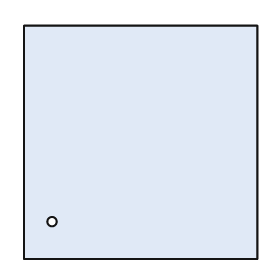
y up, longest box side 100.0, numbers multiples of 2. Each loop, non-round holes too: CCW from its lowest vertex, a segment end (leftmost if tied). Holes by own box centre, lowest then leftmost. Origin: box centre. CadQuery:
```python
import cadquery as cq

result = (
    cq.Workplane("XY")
    .moveTo(-50.0, -50.0)
    .lineTo(50.0, -50.0)
    .lineTo(50.0, 50.0)
    .lineTo(-50.0, 50.0)
    .close()
    .moveTo(-38.0, -34.0)
    .circle(2.0)
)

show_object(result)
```